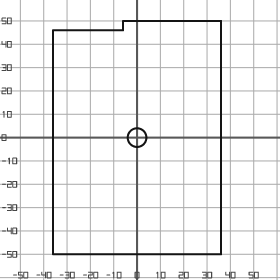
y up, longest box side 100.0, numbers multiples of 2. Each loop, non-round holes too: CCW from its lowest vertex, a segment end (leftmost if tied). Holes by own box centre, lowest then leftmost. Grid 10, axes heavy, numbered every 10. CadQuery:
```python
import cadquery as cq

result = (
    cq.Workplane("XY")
    .moveTo(-36.0, -50.0)
    .lineTo(36.0, -50.0)
    .lineTo(36.0, 50.0)
    .lineTo(-6.0, 50.0)
    .lineTo(-6.0, 46.0)
    .lineTo(-36.0, 46.0)
    .close()
    .moveTo(0.0, 0.0)
    .circle(4.0)
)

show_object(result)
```